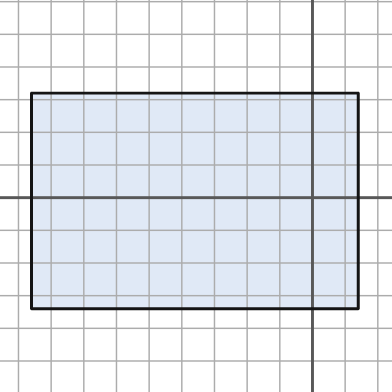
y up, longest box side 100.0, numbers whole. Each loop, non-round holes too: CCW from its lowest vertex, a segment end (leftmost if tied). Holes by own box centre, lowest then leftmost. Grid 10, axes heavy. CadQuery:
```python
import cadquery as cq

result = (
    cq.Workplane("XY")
    .moveTo(-86.0, -34.0)
    .lineTo(14.0, -34.0)
    .lineTo(14.0, 32.0)
    .lineTo(-86.0, 32.0)
    .close()
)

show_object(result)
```